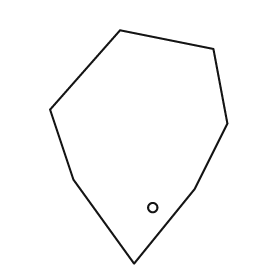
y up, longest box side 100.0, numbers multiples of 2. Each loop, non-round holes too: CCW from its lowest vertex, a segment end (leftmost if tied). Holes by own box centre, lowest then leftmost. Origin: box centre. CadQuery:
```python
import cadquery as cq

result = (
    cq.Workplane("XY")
    .moveTo(-2.0, -50.0)
    .lineTo(24.0, -18.0)
    .lineTo(38.0, 10.0)
    .lineTo(32.0, 42.0)
    .lineTo(-8.0, 50.0)
    .lineTo(-38.0, 16.0)
    .lineTo(-28.0, -14.0)
    .close()
    .moveTo(6.0, -26.0)
    .circle(2.0)
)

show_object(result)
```